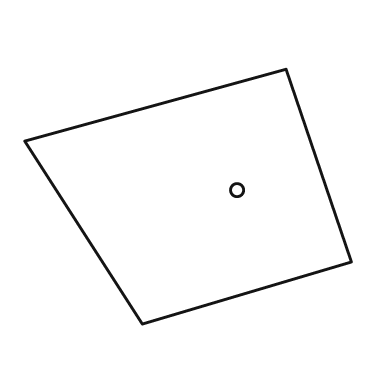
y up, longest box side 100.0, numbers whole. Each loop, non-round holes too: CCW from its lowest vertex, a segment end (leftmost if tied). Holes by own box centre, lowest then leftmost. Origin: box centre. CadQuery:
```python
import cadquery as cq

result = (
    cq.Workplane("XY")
    .moveTo(-14.0, -39.0)
    .lineTo(50.0, -20.0)
    .lineTo(30.0, 39.0)
    .lineTo(-50.0, 17.0)
    .close()
    .moveTo(15.0, 2.0)
    .circle(2.0)
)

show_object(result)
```